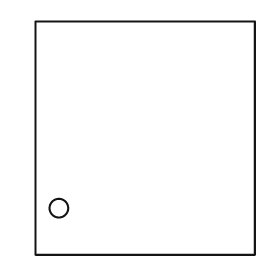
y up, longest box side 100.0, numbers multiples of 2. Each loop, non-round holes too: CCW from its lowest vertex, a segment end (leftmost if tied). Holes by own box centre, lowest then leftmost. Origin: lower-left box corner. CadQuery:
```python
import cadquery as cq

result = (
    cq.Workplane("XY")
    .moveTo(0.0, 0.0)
    .lineTo(94.0, 0.0)
    .lineTo(94.0, 100.0)
    .lineTo(0.0, 100.0)
    .close()
    .moveTo(10.0, 20.0)
    .circle(4.0)
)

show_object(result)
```